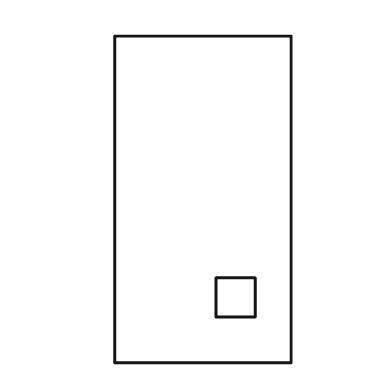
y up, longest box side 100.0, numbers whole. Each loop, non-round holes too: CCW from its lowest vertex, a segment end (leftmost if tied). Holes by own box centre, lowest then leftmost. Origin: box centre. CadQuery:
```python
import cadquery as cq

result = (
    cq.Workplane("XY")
    .moveTo(-27.0, -50.0)
    .lineTo(27.0, -50.0)
    .lineTo(27.0, 50.0)
    .lineTo(-27.0, 50.0)
    .close()
    .moveTo(4.0, -36.0)
    .lineTo(16.0, -36.0)
    .lineTo(16.0, -24.0)
    .lineTo(4.0, -24.0)
    .close()
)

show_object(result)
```